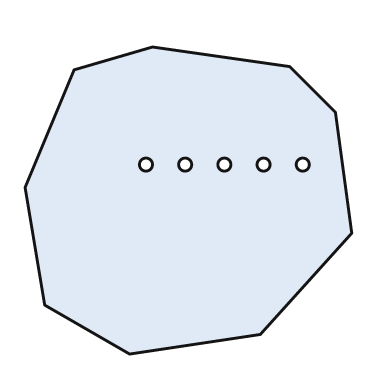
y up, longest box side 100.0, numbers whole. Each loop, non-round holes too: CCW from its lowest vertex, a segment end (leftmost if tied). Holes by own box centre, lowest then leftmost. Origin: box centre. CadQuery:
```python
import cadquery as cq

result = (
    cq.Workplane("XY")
    .moveTo(-18.0, -47.0)
    .lineTo(22.0, -41.0)
    .lineTo(50.0, -10.0)
    .lineTo(45.0, 27.0)
    .lineTo(31.0, 41.0)
    .lineTo(-11.0, 47.0)
    .lineTo(-35.0, 40.0)
    .lineTo(-50.0, 4.0)
    .lineTo(-44.0, -32.0)
    .close()
    .moveTo(-13.0, 11.0)
    .circle(2.0)
    .moveTo(-1.0, 11.0)
    .circle(2.0)
    .moveTo(11.0, 11.0)
    .circle(2.0)
    .moveTo(23.0, 11.0)
    .circle(2.0)
    .moveTo(35.0, 11.0)
    .circle(2.0)
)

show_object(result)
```